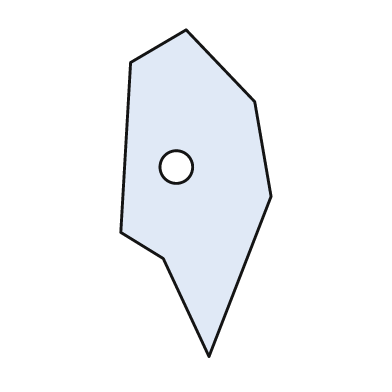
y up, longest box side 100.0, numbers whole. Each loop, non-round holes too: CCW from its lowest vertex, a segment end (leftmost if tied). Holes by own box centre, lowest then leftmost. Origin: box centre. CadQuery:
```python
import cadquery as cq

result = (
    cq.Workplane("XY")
    .moveTo(4.0, -50.0)
    .lineTo(23.0, -1.0)
    .lineTo(18.0, 28.0)
    .lineTo(-3.0, 50.0)
    .lineTo(-20.0, 40.0)
    .lineTo(-23.0, -12.0)
    .lineTo(-10.0, -20.0)
    .close()
    .moveTo(-6.0, 8.0)
    .circle(5.0)
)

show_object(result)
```